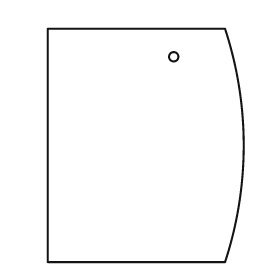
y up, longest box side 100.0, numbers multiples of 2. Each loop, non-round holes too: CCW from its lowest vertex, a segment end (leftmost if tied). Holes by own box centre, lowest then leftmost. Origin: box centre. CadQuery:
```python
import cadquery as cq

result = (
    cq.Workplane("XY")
    .moveTo(-42.0, -50.0)
    .lineTo(34.0, -50.0)
    .threePointArc((42.0, 0.0), (34.0, 50.0))
    .lineTo(-42.0, 50.0)
    .close()
    .moveTo(12.0, 38.0)
    .circle(2.0)
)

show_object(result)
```